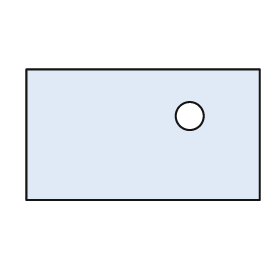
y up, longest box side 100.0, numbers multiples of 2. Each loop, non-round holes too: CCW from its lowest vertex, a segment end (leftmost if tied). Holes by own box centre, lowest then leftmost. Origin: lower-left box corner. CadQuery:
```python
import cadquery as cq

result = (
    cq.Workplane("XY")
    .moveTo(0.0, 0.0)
    .lineTo(100.0, 0.0)
    .lineTo(100.0, 56.0)
    .lineTo(0.0, 56.0)
    .close()
    .moveTo(70.0, 36.0)
    .circle(6.0)
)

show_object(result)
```